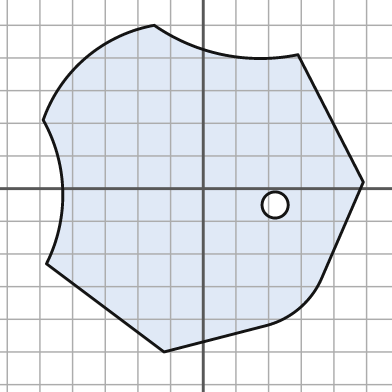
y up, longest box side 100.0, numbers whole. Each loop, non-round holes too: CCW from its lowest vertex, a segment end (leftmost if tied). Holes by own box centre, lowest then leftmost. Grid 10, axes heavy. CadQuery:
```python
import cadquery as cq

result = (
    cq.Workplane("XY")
    .moveTo(-12.0, -50.0)
    .lineTo(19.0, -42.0)
    .threePointArc((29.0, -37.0), (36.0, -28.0))
    .lineTo(49.0, 2.0)
    .lineTo(29.0, 41.0)
    .threePointArc((6.0, 41.0), (-15.0, 50.0))
    .threePointArc((-36.0, 40.0), (-49.0, 21.0))
    .threePointArc((-43.0, -1.0), (-48.0, -23.0))
    .close()
    .moveTo(22.0, -5.0)
    .circle(4.0)
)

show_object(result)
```